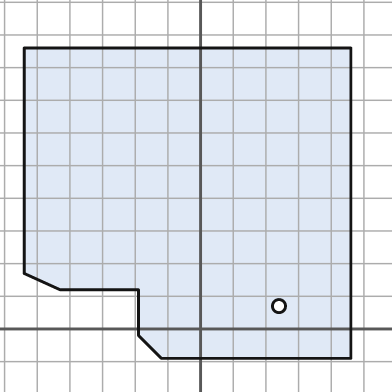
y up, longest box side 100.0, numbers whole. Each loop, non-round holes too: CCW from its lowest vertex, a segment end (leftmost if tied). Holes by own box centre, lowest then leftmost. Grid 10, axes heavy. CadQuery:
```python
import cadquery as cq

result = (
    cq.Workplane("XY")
    .moveTo(-12.0, -9.0)
    .lineTo(46.0, -9.0)
    .lineTo(46.0, 86.0)
    .lineTo(-54.0, 86.0)
    .lineTo(-54.0, 17.0)
    .lineTo(-43.0, 12.0)
    .lineTo(-19.0, 12.0)
    .lineTo(-19.0, -2.0)
    .close()
    .moveTo(24.0, 7.0)
    .circle(2.0)
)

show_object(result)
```